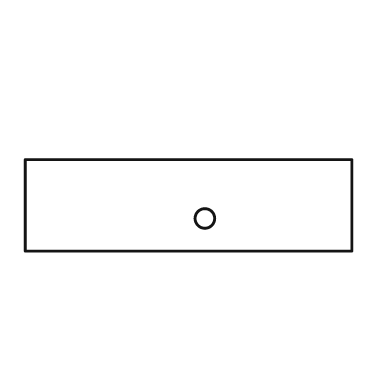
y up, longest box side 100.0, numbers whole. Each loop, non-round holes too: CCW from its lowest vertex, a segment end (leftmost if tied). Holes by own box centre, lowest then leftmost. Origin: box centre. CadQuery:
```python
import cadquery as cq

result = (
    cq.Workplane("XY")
    .moveTo(-50.0, -14.0)
    .lineTo(50.0, -14.0)
    .lineTo(50.0, 14.0)
    .lineTo(-50.0, 14.0)
    .close()
    .moveTo(5.0, -4.0)
    .circle(3.0)
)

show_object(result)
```